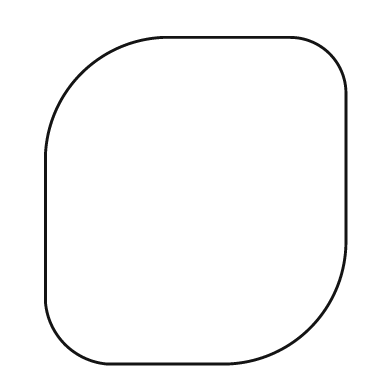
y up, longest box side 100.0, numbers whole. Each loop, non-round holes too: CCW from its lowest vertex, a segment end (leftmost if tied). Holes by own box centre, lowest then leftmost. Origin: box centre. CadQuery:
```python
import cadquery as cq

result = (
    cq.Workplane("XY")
    .moveTo(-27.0, -50.0)
    .lineTo(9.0, -50.0)
    .threePointArc((35.0, -39.0), (46.0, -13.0))
    .lineTo(46.0, 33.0)
    .threePointArc((41.0, 45.0), (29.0, 50.0))
    .lineTo(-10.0, 50.0)
    .threePointArc((-35.0, 39.0), (-46.0, 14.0))
    .lineTo(-46.0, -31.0)
    .threePointArc((-40.0, -44.0), (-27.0, -50.0))
    .close()
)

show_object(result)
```